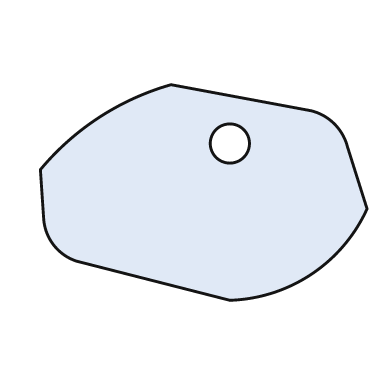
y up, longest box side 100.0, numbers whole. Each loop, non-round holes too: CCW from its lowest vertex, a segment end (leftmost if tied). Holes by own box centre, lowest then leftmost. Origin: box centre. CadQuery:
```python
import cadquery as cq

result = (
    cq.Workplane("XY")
    .moveTo(8.0, -33.0)
    .threePointArc((33.0, -25.0), (50.0, -5.0))
    .lineTo(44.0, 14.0)
    .threePointArc((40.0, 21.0), (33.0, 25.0))
    .lineTo(-10.0, 33.0)
    .threePointArc((-32.0, 23.0), (-50.0, 7.0))
    .lineTo(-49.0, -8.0)
    .threePointArc((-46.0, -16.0), (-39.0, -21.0))
    .close()
    .moveTo(8.0, 15.0)
    .circle(6.0)
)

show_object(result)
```